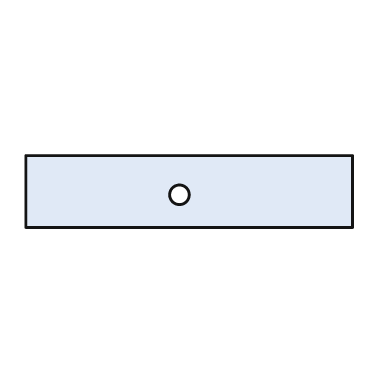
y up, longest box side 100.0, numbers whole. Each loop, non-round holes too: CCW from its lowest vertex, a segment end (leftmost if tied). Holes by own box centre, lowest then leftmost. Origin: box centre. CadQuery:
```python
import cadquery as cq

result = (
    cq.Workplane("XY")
    .moveTo(-50.0, -11.0)
    .lineTo(50.0, -11.0)
    .lineTo(50.0, 11.0)
    .lineTo(-50.0, 11.0)
    .close()
    .moveTo(-3.0, -1.0)
    .circle(3.0)
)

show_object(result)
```